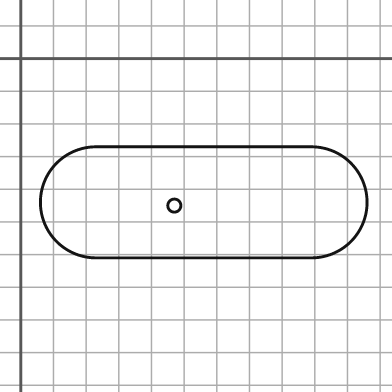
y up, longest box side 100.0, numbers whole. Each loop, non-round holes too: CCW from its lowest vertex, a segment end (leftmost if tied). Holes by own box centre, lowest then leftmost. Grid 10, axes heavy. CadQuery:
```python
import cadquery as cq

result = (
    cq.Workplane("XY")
    .moveTo(23.0, -61.0)
    .lineTo(89.0, -61.0)
    .threePointArc((106.0, -44.0), (89.0, -27.0))
    .lineTo(23.0, -27.0)
    .threePointArc((6.0, -44.0), (23.0, -61.0))
    .close()
    .moveTo(47.0, -45.0)
    .circle(2.0)
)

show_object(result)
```